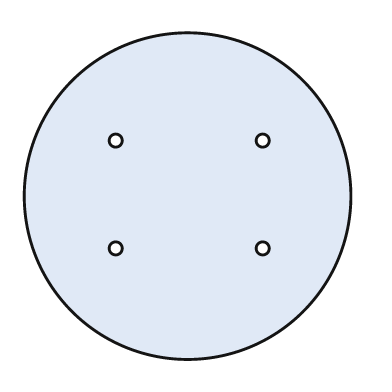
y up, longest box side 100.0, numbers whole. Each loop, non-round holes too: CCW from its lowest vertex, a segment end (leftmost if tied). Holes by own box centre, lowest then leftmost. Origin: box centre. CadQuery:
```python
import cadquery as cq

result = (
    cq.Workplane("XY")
    .moveTo(0.0, 0.0)
    .circle(50.0)
    .moveTo(-22.0, -16.0)
    .circle(2.0)
    .moveTo(23.0, -16.0)
    .circle(2.0)
    .moveTo(-22.0, 17.0)
    .circle(2.0)
    .moveTo(23.0, 17.0)
    .circle(2.0)
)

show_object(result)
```